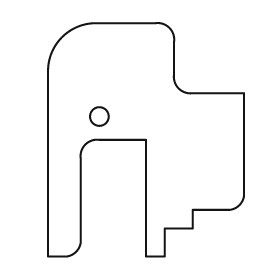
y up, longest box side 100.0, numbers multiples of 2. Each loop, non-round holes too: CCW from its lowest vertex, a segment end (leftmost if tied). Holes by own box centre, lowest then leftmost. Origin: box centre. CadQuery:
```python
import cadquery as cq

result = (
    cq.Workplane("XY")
    .moveTo(-42.0, -50.0)
    .lineTo(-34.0, -50.0)
    .threePointArc((-30.0, -48.0), (-28.0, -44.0))
    .lineTo(-28.0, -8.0)
    .threePointArc((-26.0, -2.0), (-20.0, 0.0))
    .lineTo(0.0, 0.0)
    .lineTo(0.0, -50.0)
    .lineTo(8.0, -50.0)
    .lineTo(8.0, -38.0)
    .lineTo(20.0, -38.0)
    .lineTo(20.0, -30.0)
    .lineTo(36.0, -30.0)
    .threePointArc((40.0, -28.0), (42.0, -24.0))
    .lineTo(42.0, 20.0)
    .lineTo(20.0, 20.0)
    .threePointArc((14.0, 22.0), (12.0, 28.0))
    .lineTo(12.0, 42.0)
    .threePointArc((10.0, 48.0), (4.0, 50.0))
    .lineTo(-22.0, 50.0)
    .threePointArc((-36.0, 44.0), (-42.0, 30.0))
    .close()
    .moveTo(-20.0, 10.0)
    .circle(4.0)
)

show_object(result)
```